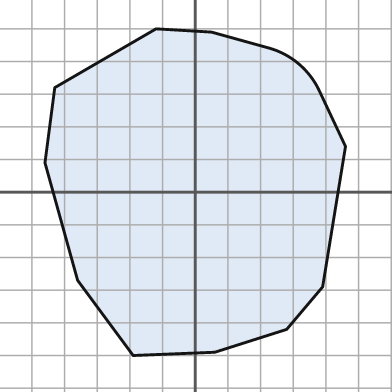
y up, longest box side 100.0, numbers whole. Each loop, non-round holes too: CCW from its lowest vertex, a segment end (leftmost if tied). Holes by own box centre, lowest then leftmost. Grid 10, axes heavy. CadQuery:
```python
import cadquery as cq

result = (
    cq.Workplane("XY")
    .moveTo(-19.0, -50.0)
    .lineTo(6.0, -49.0)
    .lineTo(28.0, -42.0)
    .lineTo(39.0, -29.0)
    .lineTo(46.0, 14.0)
    .lineTo(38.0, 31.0)
    .threePointArc((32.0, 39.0), (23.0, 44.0))
    .lineTo(5.0, 49.0)
    .lineTo(-12.0, 50.0)
    .lineTo(-43.0, 32.0)
    .lineTo(-46.0, 9.0)
    .lineTo(-36.0, -27.0)
    .close()
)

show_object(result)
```